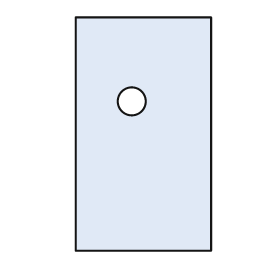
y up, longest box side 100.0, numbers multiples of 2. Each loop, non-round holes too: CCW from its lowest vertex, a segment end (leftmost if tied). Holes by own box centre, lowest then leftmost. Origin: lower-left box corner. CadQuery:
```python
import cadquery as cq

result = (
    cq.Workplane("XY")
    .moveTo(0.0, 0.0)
    .lineTo(58.0, 0.0)
    .lineTo(58.0, 100.0)
    .lineTo(0.0, 100.0)
    .close()
    .moveTo(24.0, 64.0)
    .circle(6.0)
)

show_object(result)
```